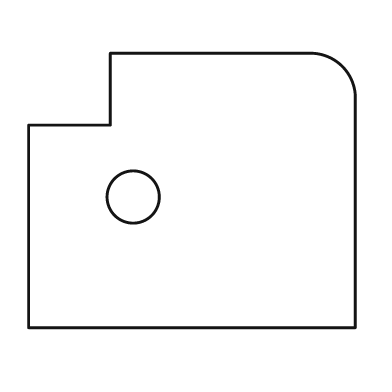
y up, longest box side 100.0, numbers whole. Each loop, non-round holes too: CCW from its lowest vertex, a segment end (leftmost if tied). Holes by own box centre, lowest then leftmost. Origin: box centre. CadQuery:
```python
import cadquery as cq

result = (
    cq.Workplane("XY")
    .moveTo(-50.0, -42.0)
    .lineTo(50.0, -42.0)
    .lineTo(50.0, 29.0)
    .threePointArc((46.0, 38.0), (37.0, 42.0))
    .lineTo(-25.0, 42.0)
    .lineTo(-25.0, 20.0)
    .lineTo(-50.0, 20.0)
    .close()
    .moveTo(-18.0, -2.0)
    .circle(8.0)
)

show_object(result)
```